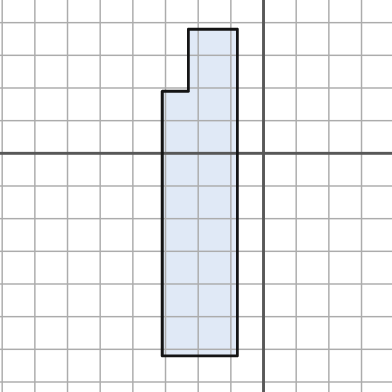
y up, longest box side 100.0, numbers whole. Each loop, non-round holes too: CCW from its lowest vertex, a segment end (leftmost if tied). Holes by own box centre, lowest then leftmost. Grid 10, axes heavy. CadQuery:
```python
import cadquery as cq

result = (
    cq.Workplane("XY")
    .moveTo(-31.0, -62.0)
    .lineTo(-8.0, -62.0)
    .lineTo(-8.0, 38.0)
    .lineTo(-23.0, 38.0)
    .lineTo(-23.0, 19.0)
    .lineTo(-31.0, 19.0)
    .close()
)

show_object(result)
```